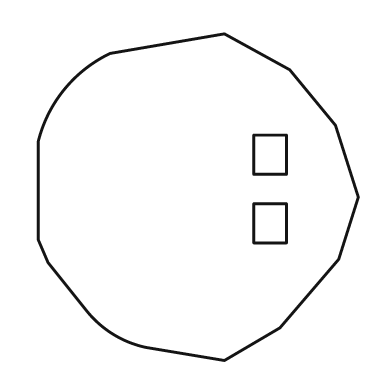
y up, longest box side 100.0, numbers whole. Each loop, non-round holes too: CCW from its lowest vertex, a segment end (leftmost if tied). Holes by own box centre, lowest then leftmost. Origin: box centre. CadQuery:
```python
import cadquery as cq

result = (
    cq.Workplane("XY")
    .moveTo(8.0, -50.0)
    .lineTo(25.0, -40.0)
    .lineTo(43.0, -19.0)
    .lineTo(49.0, 0.0)
    .lineTo(42.0, 22.0)
    .lineTo(28.0, 39.0)
    .lineTo(8.0, 50.0)
    .lineTo(-27.0, 44.0)
    .threePointArc((-41.0, 33.0), (-49.0, 17.0))
    .lineTo(-49.0, -13.0)
    .lineTo(-46.0, -20.0)
    .lineTo(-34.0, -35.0)
    .threePointArc((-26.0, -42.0), (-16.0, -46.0))
    .close()
    .moveTo(17.0, -14.0)
    .lineTo(27.0, -14.0)
    .lineTo(27.0, -2.0)
    .lineTo(17.0, -2.0)
    .close()
    .moveTo(17.0, 7.0)
    .lineTo(27.0, 7.0)
    .lineTo(27.0, 19.0)
    .lineTo(17.0, 19.0)
    .close()
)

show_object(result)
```